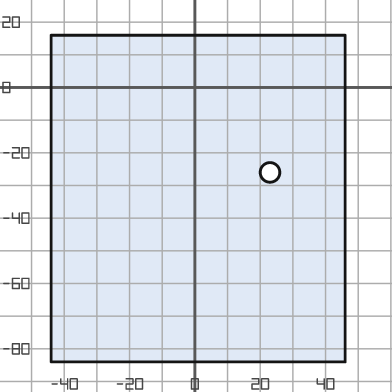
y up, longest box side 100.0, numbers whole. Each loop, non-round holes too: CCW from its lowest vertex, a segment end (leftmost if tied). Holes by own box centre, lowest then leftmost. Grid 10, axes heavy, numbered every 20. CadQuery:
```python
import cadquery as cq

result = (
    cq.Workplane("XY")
    .moveTo(-44.0, -84.0)
    .lineTo(46.0, -84.0)
    .lineTo(46.0, 16.0)
    .lineTo(-44.0, 16.0)
    .close()
    .moveTo(23.0, -26.0)
    .circle(3.0)
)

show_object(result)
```